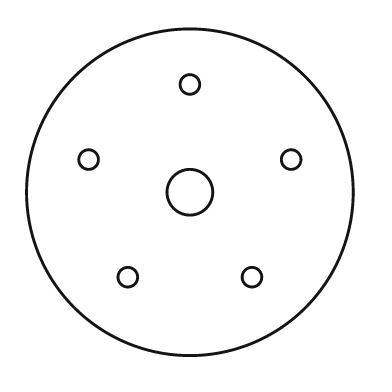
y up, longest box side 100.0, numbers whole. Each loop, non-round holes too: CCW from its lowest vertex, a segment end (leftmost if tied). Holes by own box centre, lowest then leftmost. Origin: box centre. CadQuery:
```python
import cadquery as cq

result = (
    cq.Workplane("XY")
    .moveTo(0.0, 0.0)
    .circle(50.0)
    .moveTo(-19.0, -26.0)
    .circle(3.0)
    .moveTo(19.0, -26.0)
    .circle(3.0)
    .moveTo(0.0, 0.0)
    .circle(7.0)
    .moveTo(-31.0, 10.0)
    .circle(3.0)
    .moveTo(31.0, 10.0)
    .circle(3.0)
    .moveTo(0.0, 33.0)
    .circle(3.0)
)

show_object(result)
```